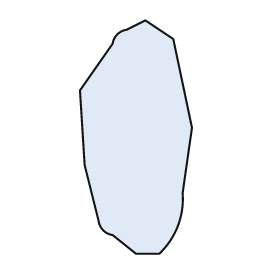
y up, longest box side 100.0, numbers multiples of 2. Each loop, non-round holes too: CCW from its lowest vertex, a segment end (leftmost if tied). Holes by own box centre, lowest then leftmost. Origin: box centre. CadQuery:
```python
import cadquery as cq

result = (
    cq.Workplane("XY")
    .moveTo(0.0, -50.0)
    .lineTo(10.0, -50.0)
    .threePointArc((18.0, -38.0), (20.0, -24.0))
    .lineTo(24.0, 4.0)
    .lineTo(16.0, 42.0)
    .lineTo(4.0, 50.0)
    .lineTo(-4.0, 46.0)
    .threePointArc((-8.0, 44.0), (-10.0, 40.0))
    .lineTo(-24.0, 20.0)
    .lineTo(-22.0, -12.0)
    .lineTo(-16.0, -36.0)
    .threePointArc((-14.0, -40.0), (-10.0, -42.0))
    .close()
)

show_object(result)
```